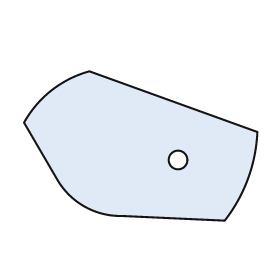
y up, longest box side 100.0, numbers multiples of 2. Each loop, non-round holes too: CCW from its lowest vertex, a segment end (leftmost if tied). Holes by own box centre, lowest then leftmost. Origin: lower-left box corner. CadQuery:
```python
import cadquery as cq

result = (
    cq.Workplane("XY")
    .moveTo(86.0, 0.0)
    .threePointArc((96.0, 18.0), (100.0, 38.0))
    .lineTo(28.0, 64.0)
    .threePointArc((12.0, 56.0), (0.0, 42.0))
    .lineTo(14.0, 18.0)
    .threePointArc((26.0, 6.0), (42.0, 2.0))
    .close()
    .moveTo(66.0, 26.0)
    .circle(4.0)
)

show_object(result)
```